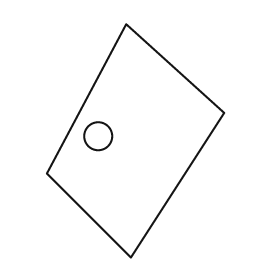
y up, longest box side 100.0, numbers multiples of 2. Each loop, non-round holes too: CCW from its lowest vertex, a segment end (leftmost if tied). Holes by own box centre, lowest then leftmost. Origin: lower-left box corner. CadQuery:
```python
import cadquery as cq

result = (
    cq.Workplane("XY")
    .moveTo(36.0, 0.0)
    .lineTo(76.0, 62.0)
    .lineTo(34.0, 100.0)
    .lineTo(0.0, 36.0)
    .close()
    .moveTo(22.0, 52.0)
    .circle(6.0)
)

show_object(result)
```